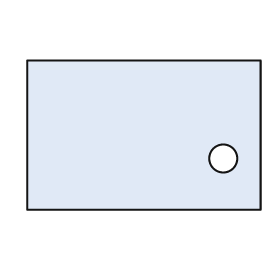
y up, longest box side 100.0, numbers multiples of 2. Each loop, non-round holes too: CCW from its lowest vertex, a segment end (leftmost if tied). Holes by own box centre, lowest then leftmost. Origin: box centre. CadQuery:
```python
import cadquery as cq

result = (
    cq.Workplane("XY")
    .moveTo(-50.0, -32.0)
    .lineTo(50.0, -32.0)
    .lineTo(50.0, 32.0)
    .lineTo(-50.0, 32.0)
    .close()
    .moveTo(34.0, -10.0)
    .circle(6.0)
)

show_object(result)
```